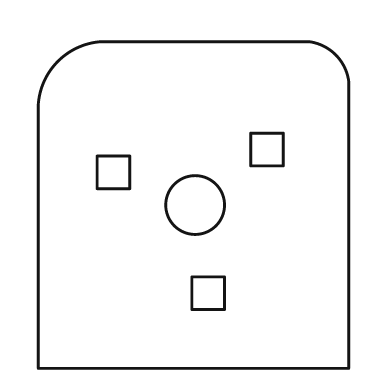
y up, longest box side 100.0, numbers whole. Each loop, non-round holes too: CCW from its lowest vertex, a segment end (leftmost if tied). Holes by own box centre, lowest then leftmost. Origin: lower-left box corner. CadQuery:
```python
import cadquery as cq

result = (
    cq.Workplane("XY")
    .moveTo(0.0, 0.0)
    .lineTo(95.0, 0.0)
    .lineTo(95.0, 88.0)
    .threePointArc((91.0, 96.0), (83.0, 100.0))
    .lineTo(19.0, 100.0)
    .threePointArc((6.0, 94.0), (0.0, 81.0))
    .close()
    .moveTo(47.0, 18.0)
    .lineTo(57.0, 18.0)
    .lineTo(57.0, 28.0)
    .lineTo(47.0, 28.0)
    .close()
    .moveTo(48.0, 50.0)
    .circle(9.0)
    .moveTo(18.0, 55.0)
    .lineTo(28.0, 55.0)
    .lineTo(28.0, 65.0)
    .lineTo(18.0, 65.0)
    .close()
    .moveTo(65.0, 62.0)
    .lineTo(75.0, 62.0)
    .lineTo(75.0, 72.0)
    .lineTo(65.0, 72.0)
    .close()
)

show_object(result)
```